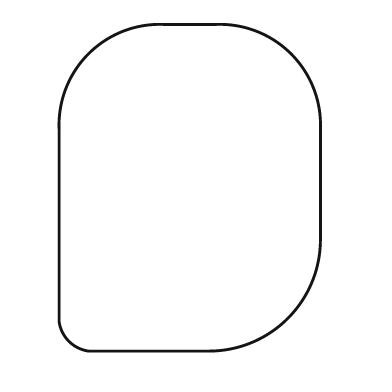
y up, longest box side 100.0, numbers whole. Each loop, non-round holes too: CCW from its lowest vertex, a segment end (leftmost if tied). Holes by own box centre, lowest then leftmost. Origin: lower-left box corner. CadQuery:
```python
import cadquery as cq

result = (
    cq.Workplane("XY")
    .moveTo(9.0, 0.0)
    .lineTo(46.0, 0.0)
    .threePointArc((70.0, 10.0), (80.0, 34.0))
    .lineTo(80.0, 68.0)
    .threePointArc((71.0, 91.0), (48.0, 100.0))
    .lineTo(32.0, 100.0)
    .threePointArc((9.0, 91.0), (0.0, 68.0))
    .lineTo(0.0, 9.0)
    .threePointArc((3.0, 3.0), (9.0, 0.0))
    .close()
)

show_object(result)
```